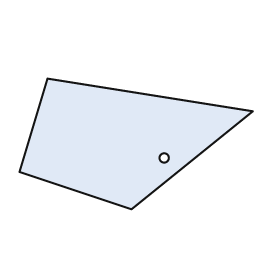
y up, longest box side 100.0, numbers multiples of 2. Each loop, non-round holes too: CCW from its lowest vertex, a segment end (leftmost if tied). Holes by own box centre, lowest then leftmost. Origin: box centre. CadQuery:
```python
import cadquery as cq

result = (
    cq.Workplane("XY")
    .moveTo(-2.0, -28.0)
    .lineTo(50.0, 14.0)
    .lineTo(-38.0, 28.0)
    .lineTo(-50.0, -12.0)
    .close()
    .moveTo(12.0, -6.0)
    .circle(2.0)
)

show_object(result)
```